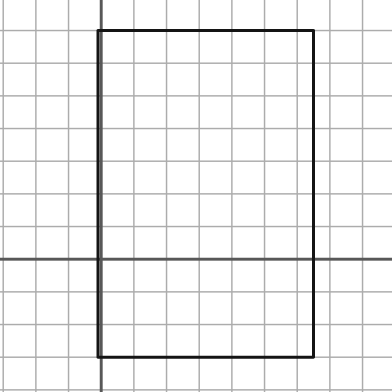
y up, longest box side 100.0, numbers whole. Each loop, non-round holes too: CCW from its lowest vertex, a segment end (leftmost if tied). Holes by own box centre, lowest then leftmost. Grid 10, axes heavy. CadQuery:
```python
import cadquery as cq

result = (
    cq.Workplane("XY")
    .moveTo(-1.0, -30.0)
    .lineTo(65.0, -30.0)
    .lineTo(65.0, 70.0)
    .lineTo(-1.0, 70.0)
    .close()
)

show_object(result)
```